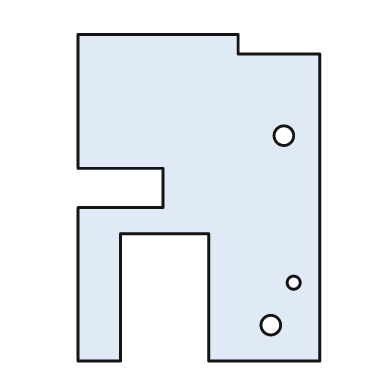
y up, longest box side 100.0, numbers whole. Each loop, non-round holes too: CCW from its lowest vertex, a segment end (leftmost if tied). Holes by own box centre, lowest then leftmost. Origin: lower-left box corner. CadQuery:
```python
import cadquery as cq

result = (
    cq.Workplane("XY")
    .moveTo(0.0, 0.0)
    .lineTo(13.0, 0.0)
    .lineTo(13.0, 39.0)
    .lineTo(40.0, 39.0)
    .lineTo(40.0, 0.0)
    .lineTo(74.0, 0.0)
    .lineTo(74.0, 94.0)
    .lineTo(49.0, 94.0)
    .lineTo(49.0, 100.0)
    .lineTo(0.0, 100.0)
    .lineTo(0.0, 59.0)
    .lineTo(26.0, 59.0)
    .lineTo(26.0, 47.0)
    .lineTo(0.0, 47.0)
    .close()
    .moveTo(59.0, 11.0)
    .circle(3.0)
    .moveTo(66.0, 24.0)
    .circle(2.0)
    .moveTo(63.0, 69.0)
    .circle(3.0)
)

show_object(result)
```